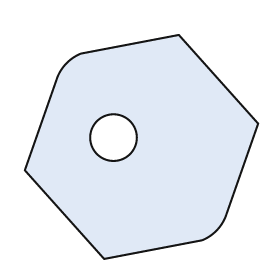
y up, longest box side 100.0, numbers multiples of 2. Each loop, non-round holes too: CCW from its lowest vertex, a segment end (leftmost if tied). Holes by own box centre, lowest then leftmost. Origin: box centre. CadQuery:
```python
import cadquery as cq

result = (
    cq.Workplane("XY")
    .moveTo(-16.0, -48.0)
    .lineTo(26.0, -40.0)
    .threePointArc((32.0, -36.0), (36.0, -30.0))
    .lineTo(50.0, 10.0)
    .lineTo(16.0, 48.0)
    .lineTo(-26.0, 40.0)
    .threePointArc((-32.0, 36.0), (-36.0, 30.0))
    .lineTo(-50.0, -10.0)
    .close()
    .moveTo(-12.0, 4.0)
    .circle(10.0)
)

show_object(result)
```